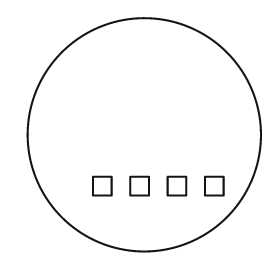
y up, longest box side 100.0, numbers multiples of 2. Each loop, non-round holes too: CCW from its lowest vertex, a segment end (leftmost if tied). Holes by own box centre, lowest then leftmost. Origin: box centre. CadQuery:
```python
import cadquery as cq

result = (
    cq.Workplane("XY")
    .moveTo(0.0, 0.0)
    .circle(50.0)
    .moveTo(-22.0, -26.0)
    .lineTo(-14.0, -26.0)
    .lineTo(-14.0, -18.0)
    .lineTo(-22.0, -18.0)
    .close()
    .moveTo(-6.0, -26.0)
    .lineTo(2.0, -26.0)
    .lineTo(2.0, -18.0)
    .lineTo(-6.0, -18.0)
    .close()
    .moveTo(10.0, -26.0)
    .lineTo(18.0, -26.0)
    .lineTo(18.0, -18.0)
    .lineTo(10.0, -18.0)
    .close()
    .moveTo(26.0, -26.0)
    .lineTo(34.0, -26.0)
    .lineTo(34.0, -18.0)
    .lineTo(26.0, -18.0)
    .close()
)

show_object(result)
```